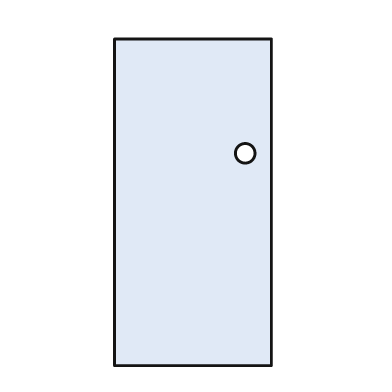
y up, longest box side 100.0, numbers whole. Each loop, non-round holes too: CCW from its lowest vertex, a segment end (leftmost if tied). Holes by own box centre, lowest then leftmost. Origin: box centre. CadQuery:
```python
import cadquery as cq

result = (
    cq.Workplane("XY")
    .moveTo(-24.0, -50.0)
    .lineTo(24.0, -50.0)
    .lineTo(24.0, 50.0)
    .lineTo(-24.0, 50.0)
    .close()
    .moveTo(16.0, 15.0)
    .circle(3.0)
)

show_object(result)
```